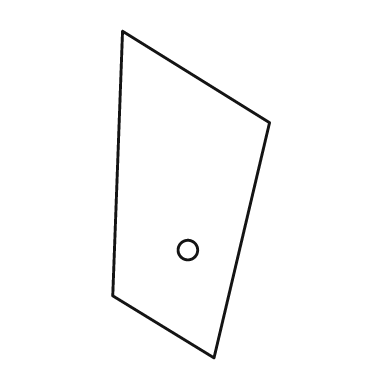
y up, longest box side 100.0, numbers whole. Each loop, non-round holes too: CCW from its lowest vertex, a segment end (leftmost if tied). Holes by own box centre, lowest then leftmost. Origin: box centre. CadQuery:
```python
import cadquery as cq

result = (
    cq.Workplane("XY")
    .moveTo(7.0, -50.0)
    .lineTo(24.0, 22.0)
    .lineTo(-21.0, 50.0)
    .lineTo(-24.0, -31.0)
    .close()
    .moveTo(-1.0, -17.0)
    .circle(3.0)
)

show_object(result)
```